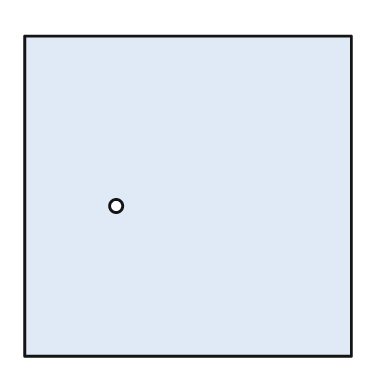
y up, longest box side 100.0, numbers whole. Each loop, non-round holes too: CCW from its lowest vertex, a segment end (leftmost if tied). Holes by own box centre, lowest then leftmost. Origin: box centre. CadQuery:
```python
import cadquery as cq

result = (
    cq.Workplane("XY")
    .moveTo(-50.0, -49.0)
    .lineTo(50.0, -49.0)
    .lineTo(50.0, 49.0)
    .lineTo(-50.0, 49.0)
    .close()
    .moveTo(-22.0, -3.0)
    .circle(2.0)
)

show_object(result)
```